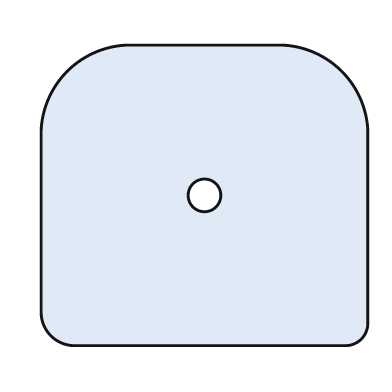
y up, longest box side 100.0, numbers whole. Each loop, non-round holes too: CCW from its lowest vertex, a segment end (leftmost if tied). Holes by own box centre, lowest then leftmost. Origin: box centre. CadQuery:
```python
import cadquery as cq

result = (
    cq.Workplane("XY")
    .moveTo(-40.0, -46.0)
    .lineTo(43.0, -46.0)
    .threePointArc((48.0, -44.0), (50.0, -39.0))
    .lineTo(50.0, 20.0)
    .threePointArc((42.0, 38.0), (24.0, 46.0))
    .lineTo(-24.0, 46.0)
    .threePointArc((-42.0, 38.0), (-50.0, 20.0))
    .lineTo(-50.0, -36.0)
    .threePointArc((-47.0, -43.0), (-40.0, -46.0))
    .close()
    .moveTo(0.0, 0.0)
    .circle(5.0)
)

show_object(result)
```